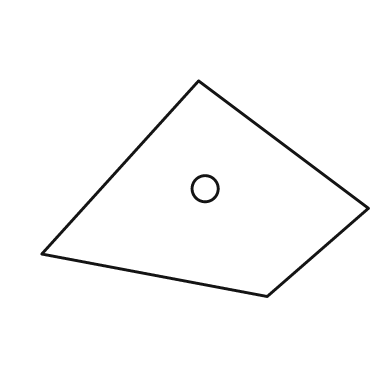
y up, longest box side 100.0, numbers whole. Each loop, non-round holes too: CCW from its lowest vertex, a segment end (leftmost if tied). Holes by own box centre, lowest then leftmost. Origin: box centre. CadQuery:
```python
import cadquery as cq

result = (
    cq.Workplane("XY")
    .moveTo(19.0, -33.0)
    .lineTo(50.0, -6.0)
    .lineTo(-2.0, 33.0)
    .lineTo(-50.0, -20.0)
    .close()
    .moveTo(0.0, 0.0)
    .circle(4.0)
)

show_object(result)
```